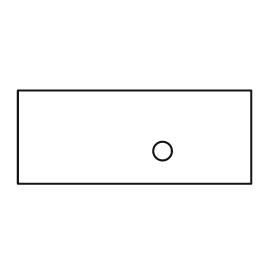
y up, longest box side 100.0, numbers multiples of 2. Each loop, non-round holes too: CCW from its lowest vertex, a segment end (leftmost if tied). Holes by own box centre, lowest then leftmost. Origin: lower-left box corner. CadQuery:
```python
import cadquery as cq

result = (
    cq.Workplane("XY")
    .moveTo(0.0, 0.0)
    .lineTo(100.0, 0.0)
    .lineTo(100.0, 40.0)
    .lineTo(0.0, 40.0)
    .close()
    .moveTo(62.0, 14.0)
    .circle(4.0)
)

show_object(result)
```